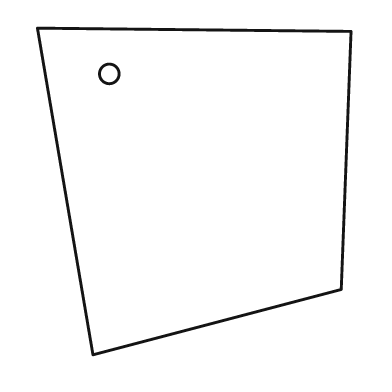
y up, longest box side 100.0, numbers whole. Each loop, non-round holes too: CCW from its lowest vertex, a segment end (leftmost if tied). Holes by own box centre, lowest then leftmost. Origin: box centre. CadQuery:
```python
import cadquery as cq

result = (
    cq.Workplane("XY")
    .moveTo(-31.0, -50.0)
    .lineTo(45.0, -30.0)
    .lineTo(48.0, 49.0)
    .lineTo(-48.0, 50.0)
    .close()
    .moveTo(-26.0, 36.0)
    .circle(3.0)
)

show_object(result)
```